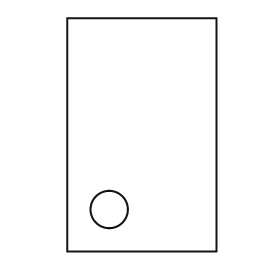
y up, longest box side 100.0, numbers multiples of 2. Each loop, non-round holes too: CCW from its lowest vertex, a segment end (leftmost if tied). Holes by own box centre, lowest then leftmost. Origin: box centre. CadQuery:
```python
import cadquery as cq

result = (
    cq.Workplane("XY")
    .moveTo(-32.0, -50.0)
    .lineTo(32.0, -50.0)
    .lineTo(32.0, 50.0)
    .lineTo(-32.0, 50.0)
    .close()
    .moveTo(-14.0, -32.0)
    .circle(8.0)
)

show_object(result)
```